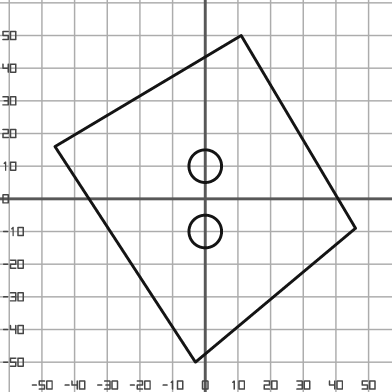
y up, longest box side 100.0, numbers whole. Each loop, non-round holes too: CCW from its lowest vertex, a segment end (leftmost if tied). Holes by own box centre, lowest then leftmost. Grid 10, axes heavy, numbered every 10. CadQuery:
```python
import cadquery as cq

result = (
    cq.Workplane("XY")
    .moveTo(-3.0, -50.0)
    .lineTo(46.0, -9.0)
    .lineTo(11.0, 50.0)
    .lineTo(-46.0, 16.0)
    .close()
    .moveTo(0.0, -10.0)
    .circle(5.0)
    .moveTo(0.0, 10.0)
    .circle(5.0)
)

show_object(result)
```